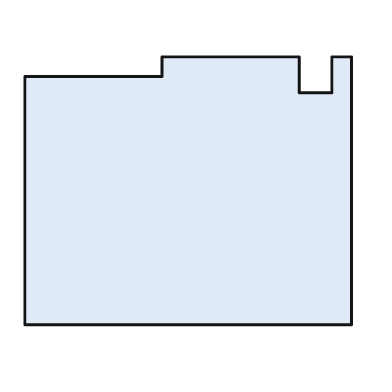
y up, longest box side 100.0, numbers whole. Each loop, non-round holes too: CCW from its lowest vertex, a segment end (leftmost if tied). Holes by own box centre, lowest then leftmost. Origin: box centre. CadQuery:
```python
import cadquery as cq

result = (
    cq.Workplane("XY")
    .moveTo(-50.0, -41.0)
    .lineTo(50.0, -41.0)
    .lineTo(50.0, 41.0)
    .lineTo(44.0, 41.0)
    .lineTo(44.0, 30.0)
    .lineTo(34.0, 30.0)
    .lineTo(34.0, 41.0)
    .lineTo(-8.0, 41.0)
    .lineTo(-8.0, 35.0)
    .lineTo(-50.0, 35.0)
    .close()
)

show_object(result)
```